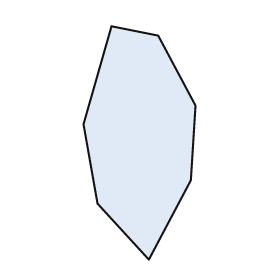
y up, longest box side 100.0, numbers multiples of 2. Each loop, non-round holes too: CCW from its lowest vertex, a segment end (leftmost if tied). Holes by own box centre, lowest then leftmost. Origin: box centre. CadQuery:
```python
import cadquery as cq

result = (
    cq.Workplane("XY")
    .moveTo(4.0, -50.0)
    .lineTo(22.0, -16.0)
    .lineTo(24.0, 16.0)
    .lineTo(8.0, 46.0)
    .lineTo(-12.0, 50.0)
    .lineTo(-24.0, 8.0)
    .lineTo(-18.0, -26.0)
    .close()
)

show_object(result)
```